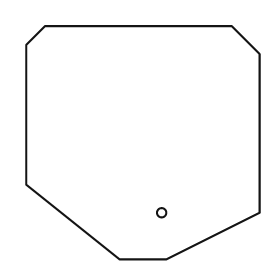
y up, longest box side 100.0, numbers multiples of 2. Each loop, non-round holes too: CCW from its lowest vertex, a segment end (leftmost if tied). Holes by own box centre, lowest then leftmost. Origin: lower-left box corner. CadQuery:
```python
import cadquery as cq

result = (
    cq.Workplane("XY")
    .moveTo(40.0, 0.0)
    .lineTo(60.0, 0.0)
    .lineTo(100.0, 20.0)
    .lineTo(100.0, 88.0)
    .lineTo(88.0, 100.0)
    .lineTo(8.0, 100.0)
    .lineTo(0.0, 92.0)
    .lineTo(0.0, 32.0)
    .close()
    .moveTo(58.0, 20.0)
    .circle(2.0)
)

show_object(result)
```